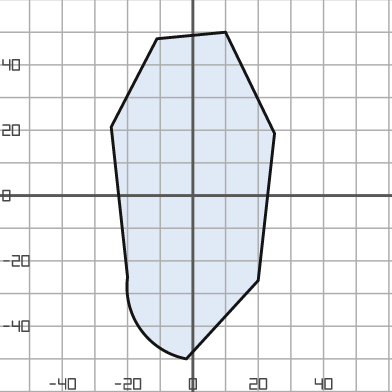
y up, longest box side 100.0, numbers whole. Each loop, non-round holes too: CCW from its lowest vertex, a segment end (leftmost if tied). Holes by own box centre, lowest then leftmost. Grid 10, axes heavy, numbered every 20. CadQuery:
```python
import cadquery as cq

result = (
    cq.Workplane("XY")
    .moveTo(-2.0, -50.0)
    .lineTo(20.0, -26.0)
    .lineTo(25.0, 19.0)
    .lineTo(10.0, 50.0)
    .lineTo(-11.0, 48.0)
    .lineTo(-25.0, 21.0)
    .lineTo(-20.0, -25.0)
    .threePointArc((-16.0, -41.0), (-2.0, -50.0))
    .close()
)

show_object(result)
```